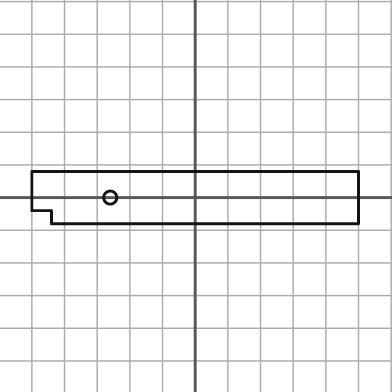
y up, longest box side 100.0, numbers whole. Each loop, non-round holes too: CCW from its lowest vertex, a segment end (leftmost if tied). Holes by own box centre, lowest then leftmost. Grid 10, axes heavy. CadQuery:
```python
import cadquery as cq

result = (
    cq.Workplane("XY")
    .moveTo(-44.0, -8.0)
    .lineTo(50.0, -8.0)
    .lineTo(50.0, 8.0)
    .lineTo(-50.0, 8.0)
    .lineTo(-50.0, -4.0)
    .lineTo(-44.0, -4.0)
    .close()
    .moveTo(-26.0, 0.0)
    .circle(2.0)
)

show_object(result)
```